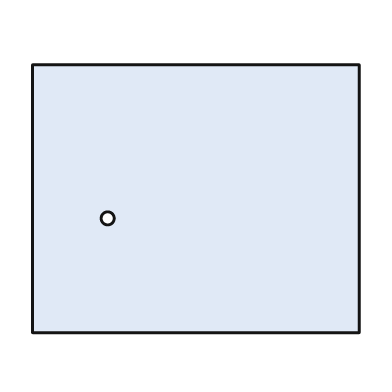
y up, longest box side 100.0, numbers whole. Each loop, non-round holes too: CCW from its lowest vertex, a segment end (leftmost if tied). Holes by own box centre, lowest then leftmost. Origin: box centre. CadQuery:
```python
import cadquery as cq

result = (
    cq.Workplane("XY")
    .moveTo(-50.0, -41.0)
    .lineTo(50.0, -41.0)
    .lineTo(50.0, 41.0)
    .lineTo(-50.0, 41.0)
    .close()
    .moveTo(-27.0, -6.0)
    .circle(2.0)
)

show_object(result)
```